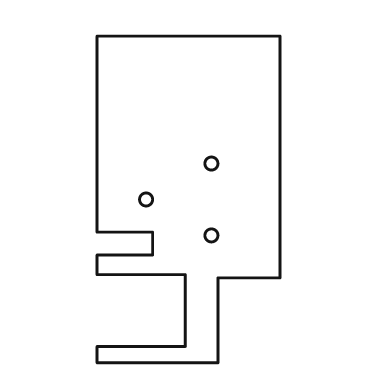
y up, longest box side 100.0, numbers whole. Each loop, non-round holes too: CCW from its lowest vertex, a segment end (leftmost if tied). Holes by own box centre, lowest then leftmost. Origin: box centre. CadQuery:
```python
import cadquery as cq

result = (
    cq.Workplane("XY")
    .moveTo(-28.0, -50.0)
    .lineTo(9.0, -50.0)
    .lineTo(9.0, -24.0)
    .lineTo(28.0, -24.0)
    .lineTo(28.0, 50.0)
    .lineTo(-28.0, 50.0)
    .lineTo(-28.0, -10.0)
    .lineTo(-11.0, -10.0)
    .lineTo(-11.0, -17.0)
    .lineTo(-28.0, -17.0)
    .lineTo(-28.0, -23.0)
    .lineTo(-1.0, -23.0)
    .lineTo(-1.0, -45.0)
    .lineTo(-28.0, -45.0)
    .close()
    .moveTo(7.0, -11.0)
    .circle(2.0)
    .moveTo(-13.0, 0.0)
    .circle(2.0)
    .moveTo(7.0, 11.0)
    .circle(2.0)
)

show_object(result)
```